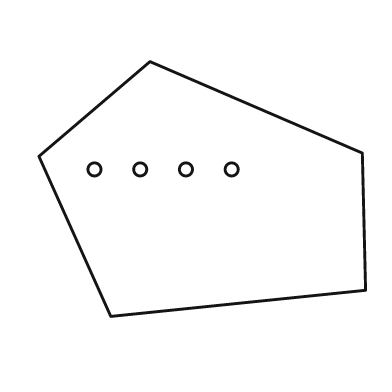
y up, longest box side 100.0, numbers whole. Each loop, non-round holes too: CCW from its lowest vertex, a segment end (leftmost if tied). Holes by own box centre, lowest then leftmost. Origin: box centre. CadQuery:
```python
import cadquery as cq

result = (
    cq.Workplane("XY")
    .moveTo(-28.0, -39.0)
    .lineTo(50.0, -31.0)
    .lineTo(49.0, 11.0)
    .lineTo(-16.0, 39.0)
    .lineTo(-50.0, 10.0)
    .close()
    .moveTo(-33.0, 6.0)
    .circle(2.0)
    .moveTo(-19.0, 6.0)
    .circle(2.0)
    .moveTo(-5.0, 6.0)
    .circle(2.0)
    .moveTo(9.0, 6.0)
    .circle(2.0)
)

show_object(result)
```